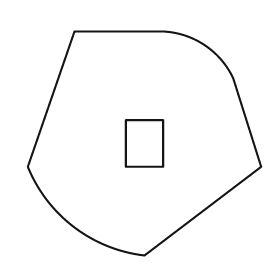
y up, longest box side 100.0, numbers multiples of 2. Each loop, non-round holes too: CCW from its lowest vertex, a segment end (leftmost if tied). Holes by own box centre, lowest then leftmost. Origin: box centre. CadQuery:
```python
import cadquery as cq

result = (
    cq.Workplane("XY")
    .moveTo(0.0, -48.0)
    .lineTo(50.0, -10.0)
    .lineTo(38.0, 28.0)
    .threePointArc((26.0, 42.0), (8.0, 48.0))
    .lineTo(-30.0, 48.0)
    .lineTo(-50.0, -10.0)
    .threePointArc((-30.0, -36.0), (0.0, -48.0))
    .close()
    .moveTo(-8.0, -10.0)
    .lineTo(8.0, -10.0)
    .lineTo(8.0, 10.0)
    .lineTo(-8.0, 10.0)
    .close()
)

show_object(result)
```